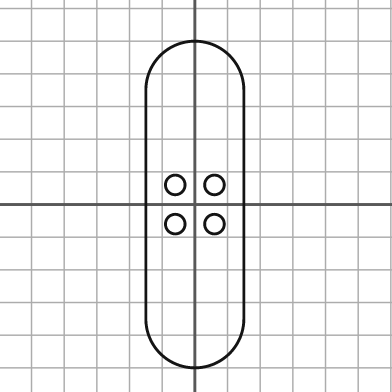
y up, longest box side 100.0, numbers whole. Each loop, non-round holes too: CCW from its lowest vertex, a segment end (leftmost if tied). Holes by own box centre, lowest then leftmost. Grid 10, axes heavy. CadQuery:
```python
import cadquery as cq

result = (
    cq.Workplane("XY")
    .moveTo(-15.0, -35.0)
    .threePointArc((0.0, -50.0), (15.0, -35.0))
    .lineTo(15.0, 35.0)
    .threePointArc((0.0, 50.0), (-15.0, 35.0))
    .close()
    .moveTo(-6.0, -6.0)
    .circle(3.0)
    .moveTo(6.0, -6.0)
    .circle(3.0)
    .moveTo(-6.0, 6.0)
    .circle(3.0)
    .moveTo(6.0, 6.0)
    .circle(3.0)
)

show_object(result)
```